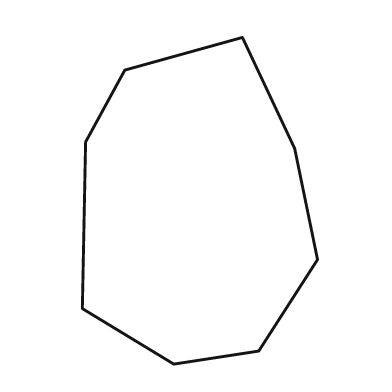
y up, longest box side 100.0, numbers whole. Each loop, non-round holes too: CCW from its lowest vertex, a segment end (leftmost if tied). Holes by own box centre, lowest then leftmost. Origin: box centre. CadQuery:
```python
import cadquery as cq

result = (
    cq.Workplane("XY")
    .moveTo(-8.0, -50.0)
    .lineTo(18.0, -46.0)
    .lineTo(36.0, -18.0)
    .lineTo(29.0, 16.0)
    .lineTo(13.0, 50.0)
    .lineTo(-23.0, 40.0)
    .lineTo(-35.0, 18.0)
    .lineTo(-36.0, -33.0)
    .close()
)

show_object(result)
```